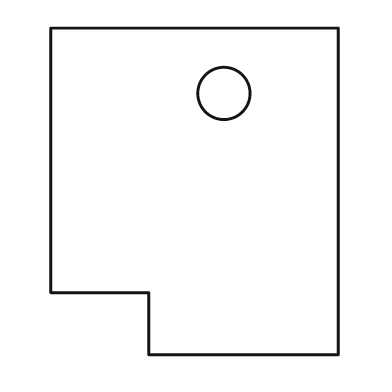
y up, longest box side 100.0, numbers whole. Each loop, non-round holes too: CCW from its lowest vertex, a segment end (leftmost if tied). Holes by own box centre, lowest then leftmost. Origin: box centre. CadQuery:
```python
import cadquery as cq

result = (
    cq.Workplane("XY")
    .moveTo(-14.0, -50.0)
    .lineTo(44.0, -50.0)
    .lineTo(44.0, 50.0)
    .lineTo(-44.0, 50.0)
    .lineTo(-44.0, -31.0)
    .lineTo(-14.0, -31.0)
    .close()
    .moveTo(9.0, 30.0)
    .circle(8.0)
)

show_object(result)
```